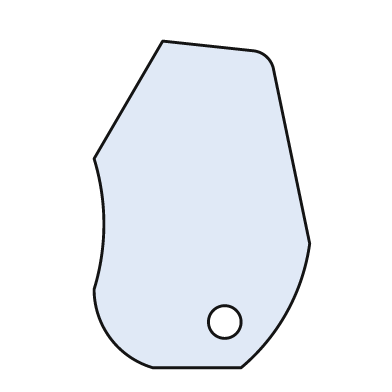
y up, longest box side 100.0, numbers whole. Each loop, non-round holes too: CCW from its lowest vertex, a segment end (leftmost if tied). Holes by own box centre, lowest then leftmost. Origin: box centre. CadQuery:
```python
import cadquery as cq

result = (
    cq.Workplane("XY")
    .moveTo(-15.0, -50.0)
    .lineTo(12.0, -50.0)
    .threePointArc((26.0, -33.0), (33.0, -12.0))
    .lineTo(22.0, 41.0)
    .threePointArc((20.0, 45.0), (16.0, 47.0))
    .lineTo(-12.0, 50.0)
    .lineTo(-33.0, 14.0)
    .threePointArc((-30.0, -6.0), (-33.0, -26.0))
    .threePointArc((-28.0, -41.0), (-15.0, -50.0))
    .close()
    .moveTo(7.0, -36.0)
    .circle(5.0)
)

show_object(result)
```